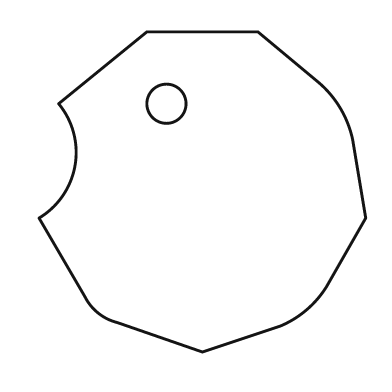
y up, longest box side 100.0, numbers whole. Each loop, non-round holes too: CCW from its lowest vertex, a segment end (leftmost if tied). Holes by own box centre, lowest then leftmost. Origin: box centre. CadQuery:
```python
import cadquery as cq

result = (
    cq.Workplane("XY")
    .moveTo(0.0, -49.0)
    .lineTo(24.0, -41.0)
    .threePointArc((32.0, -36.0), (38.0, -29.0))
    .lineTo(50.0, -8.0)
    .lineTo(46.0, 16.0)
    .threePointArc((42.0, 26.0), (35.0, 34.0))
    .lineTo(17.0, 49.0)
    .lineTo(-17.0, 49.0)
    .lineTo(-44.0, 27.0)
    .threePointArc((-39.0, 8.0), (-50.0, -8.0))
    .lineTo(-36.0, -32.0)
    .threePointArc((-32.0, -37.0), (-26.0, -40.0))
    .close()
    .moveTo(-11.0, 27.0)
    .circle(6.0)
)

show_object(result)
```